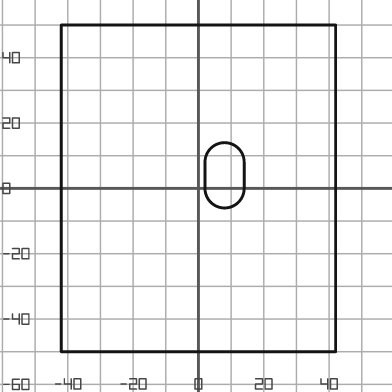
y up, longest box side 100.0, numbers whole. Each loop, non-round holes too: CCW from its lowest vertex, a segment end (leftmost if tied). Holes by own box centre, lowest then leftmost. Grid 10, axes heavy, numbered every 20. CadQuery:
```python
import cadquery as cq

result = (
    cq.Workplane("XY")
    .moveTo(-42.0, -50.0)
    .lineTo(42.0, -50.0)
    .lineTo(42.0, 50.0)
    .lineTo(-42.0, 50.0)
    .close()
    .moveTo(2.0, 0.0)
    .threePointArc((8.0, -6.0), (14.0, 0.0))
    .lineTo(14.0, 8.0)
    .threePointArc((8.0, 14.0), (2.0, 8.0))
    .close()
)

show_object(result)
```